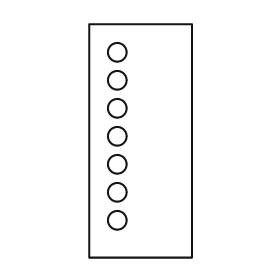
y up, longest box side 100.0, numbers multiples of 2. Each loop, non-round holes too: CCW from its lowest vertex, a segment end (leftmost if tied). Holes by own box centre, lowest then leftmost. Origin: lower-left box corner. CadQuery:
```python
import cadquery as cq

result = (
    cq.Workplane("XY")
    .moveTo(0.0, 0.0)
    .lineTo(44.0, 0.0)
    .lineTo(44.0, 100.0)
    .lineTo(0.0, 100.0)
    .close()
    .moveTo(12.0, 16.0)
    .circle(4.0)
    .moveTo(12.0, 28.0)
    .circle(4.0)
    .moveTo(12.0, 40.0)
    .circle(4.0)
    .moveTo(12.0, 52.0)
    .circle(4.0)
    .moveTo(12.0, 64.0)
    .circle(4.0)
    .moveTo(12.0, 76.0)
    .circle(4.0)
    .moveTo(12.0, 88.0)
    .circle(4.0)
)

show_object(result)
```